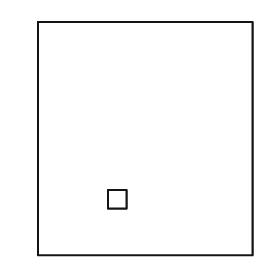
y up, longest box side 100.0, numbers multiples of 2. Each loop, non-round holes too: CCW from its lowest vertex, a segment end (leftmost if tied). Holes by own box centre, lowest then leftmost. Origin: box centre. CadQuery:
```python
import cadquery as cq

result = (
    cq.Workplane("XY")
    .moveTo(-46.0, -50.0)
    .lineTo(46.0, -50.0)
    .lineTo(46.0, 50.0)
    .lineTo(-46.0, 50.0)
    .close()
    .moveTo(-16.0, -30.0)
    .lineTo(-8.0, -30.0)
    .lineTo(-8.0, -22.0)
    .lineTo(-16.0, -22.0)
    .close()
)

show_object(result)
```